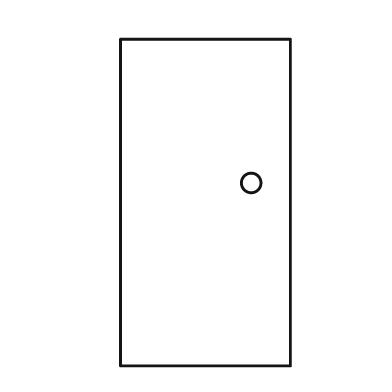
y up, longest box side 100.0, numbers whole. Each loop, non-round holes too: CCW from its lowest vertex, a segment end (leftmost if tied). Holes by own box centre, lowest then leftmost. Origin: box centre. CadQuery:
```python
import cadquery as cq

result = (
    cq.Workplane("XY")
    .moveTo(-26.0, -50.0)
    .lineTo(26.0, -50.0)
    .lineTo(26.0, 50.0)
    .lineTo(-26.0, 50.0)
    .close()
    .moveTo(14.0, 6.0)
    .circle(3.0)
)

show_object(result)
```